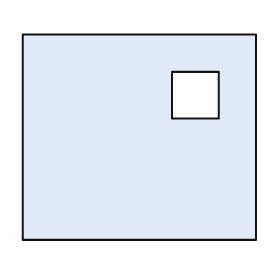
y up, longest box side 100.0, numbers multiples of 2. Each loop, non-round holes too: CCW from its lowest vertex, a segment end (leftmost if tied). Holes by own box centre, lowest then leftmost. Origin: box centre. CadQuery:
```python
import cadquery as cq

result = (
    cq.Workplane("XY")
    .moveTo(-50.0, -44.0)
    .lineTo(50.0, -44.0)
    .lineTo(50.0, 44.0)
    .lineTo(-50.0, 44.0)
    .close()
    .moveTo(14.0, 8.0)
    .lineTo(34.0, 8.0)
    .lineTo(34.0, 28.0)
    .lineTo(14.0, 28.0)
    .close()
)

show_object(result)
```